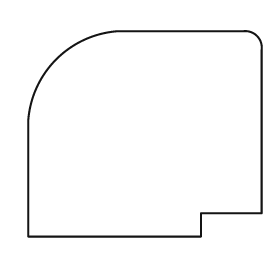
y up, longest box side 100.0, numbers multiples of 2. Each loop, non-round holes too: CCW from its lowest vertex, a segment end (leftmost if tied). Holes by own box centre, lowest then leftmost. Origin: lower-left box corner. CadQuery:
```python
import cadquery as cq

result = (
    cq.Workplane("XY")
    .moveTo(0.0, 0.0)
    .lineTo(74.0, 0.0)
    .lineTo(74.0, 10.0)
    .lineTo(100.0, 10.0)
    .lineTo(100.0, 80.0)
    .threePointArc((98.0, 86.0), (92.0, 88.0))
    .lineTo(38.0, 88.0)
    .threePointArc((12.0, 76.0), (0.0, 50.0))
    .close()
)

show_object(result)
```